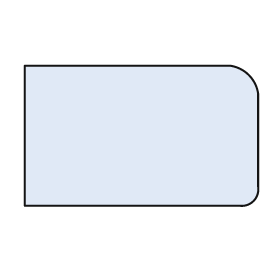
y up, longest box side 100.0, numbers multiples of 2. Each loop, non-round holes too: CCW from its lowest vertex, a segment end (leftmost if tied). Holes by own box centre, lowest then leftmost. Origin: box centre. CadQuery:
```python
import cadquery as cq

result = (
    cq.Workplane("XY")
    .moveTo(-50.0, -30.0)
    .lineTo(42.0, -30.0)
    .threePointArc((48.0, -28.0), (50.0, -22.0))
    .lineTo(50.0, 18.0)
    .threePointArc((46.0, 26.0), (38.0, 30.0))
    .lineTo(-50.0, 30.0)
    .close()
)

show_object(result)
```